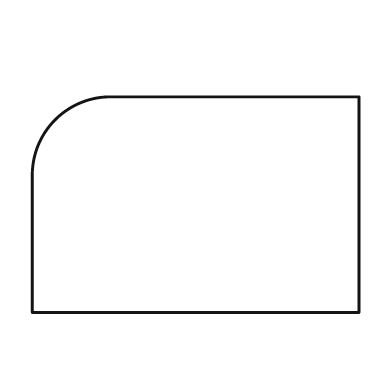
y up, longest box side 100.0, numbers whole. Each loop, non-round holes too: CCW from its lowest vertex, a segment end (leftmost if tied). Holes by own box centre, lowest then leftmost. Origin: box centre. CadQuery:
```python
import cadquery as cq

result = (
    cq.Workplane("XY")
    .moveTo(-50.0, -33.0)
    .lineTo(50.0, -33.0)
    .lineTo(50.0, 33.0)
    .lineTo(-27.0, 33.0)
    .threePointArc((-43.0, 26.0), (-50.0, 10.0))
    .close()
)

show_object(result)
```